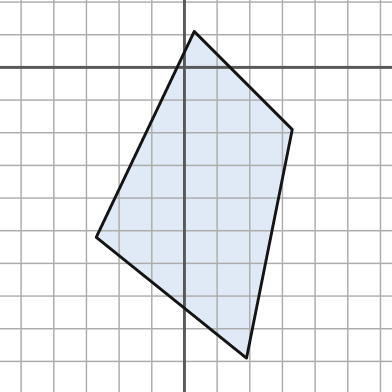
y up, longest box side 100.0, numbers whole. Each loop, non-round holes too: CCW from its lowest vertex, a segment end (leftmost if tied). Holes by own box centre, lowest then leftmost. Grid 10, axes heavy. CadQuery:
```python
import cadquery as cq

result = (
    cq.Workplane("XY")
    .moveTo(19.0, -89.0)
    .lineTo(33.0, -19.0)
    .lineTo(3.0, 11.0)
    .lineTo(-27.0, -52.0)
    .close()
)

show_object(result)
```